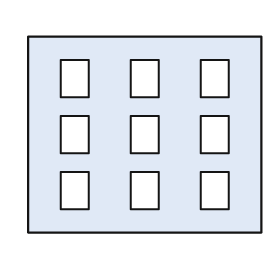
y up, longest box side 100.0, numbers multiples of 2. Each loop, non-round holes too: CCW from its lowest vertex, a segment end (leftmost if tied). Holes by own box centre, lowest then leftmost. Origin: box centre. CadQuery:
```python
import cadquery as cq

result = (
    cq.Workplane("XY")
    .moveTo(-50.0, -42.0)
    .lineTo(50.0, -42.0)
    .lineTo(50.0, 42.0)
    .lineTo(-50.0, 42.0)
    .close()
    .moveTo(-36.0, -32.0)
    .lineTo(-24.0, -32.0)
    .lineTo(-24.0, -16.0)
    .lineTo(-36.0, -16.0)
    .close()
    .moveTo(-6.0, -32.0)
    .lineTo(6.0, -32.0)
    .lineTo(6.0, -16.0)
    .lineTo(-6.0, -16.0)
    .close()
    .moveTo(24.0, -32.0)
    .lineTo(36.0, -32.0)
    .lineTo(36.0, -16.0)
    .lineTo(24.0, -16.0)
    .close()
    .moveTo(-36.0, -8.0)
    .lineTo(-24.0, -8.0)
    .lineTo(-24.0, 8.0)
    .lineTo(-36.0, 8.0)
    .close()
    .moveTo(-6.0, -8.0)
    .lineTo(6.0, -8.0)
    .lineTo(6.0, 8.0)
    .lineTo(-6.0, 8.0)
    .close()
    .moveTo(24.0, -8.0)
    .lineTo(36.0, -8.0)
    .lineTo(36.0, 8.0)
    .lineTo(24.0, 8.0)
    .close()
    .moveTo(-36.0, 16.0)
    .lineTo(-24.0, 16.0)
    .lineTo(-24.0, 32.0)
    .lineTo(-36.0, 32.0)
    .close()
    .moveTo(-6.0, 16.0)
    .lineTo(6.0, 16.0)
    .lineTo(6.0, 32.0)
    .lineTo(-6.0, 32.0)
    .close()
    .moveTo(24.0, 16.0)
    .lineTo(36.0, 16.0)
    .lineTo(36.0, 32.0)
    .lineTo(24.0, 32.0)
    .close()
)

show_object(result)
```